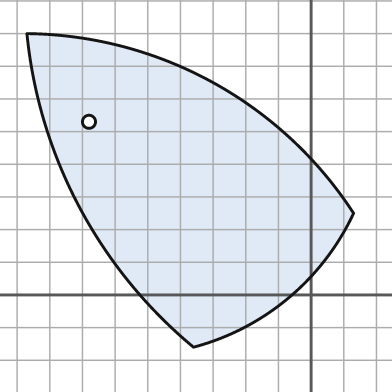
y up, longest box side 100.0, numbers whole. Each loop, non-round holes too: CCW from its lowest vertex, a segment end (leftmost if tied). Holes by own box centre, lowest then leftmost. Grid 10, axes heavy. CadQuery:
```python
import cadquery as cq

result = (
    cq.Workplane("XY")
    .moveTo(-36.0, -16.0)
    .threePointArc((-7.0, -1.0), (13.0, 25.0))
    .threePointArc((-30.0, 65.0), (-87.0, 80.0))
    .threePointArc((-71.0, 27.0), (-36.0, -16.0))
    .close()
    .moveTo(-68.0, 53.0)
    .circle(2.0)
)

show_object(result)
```